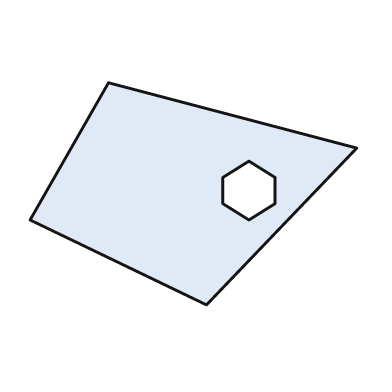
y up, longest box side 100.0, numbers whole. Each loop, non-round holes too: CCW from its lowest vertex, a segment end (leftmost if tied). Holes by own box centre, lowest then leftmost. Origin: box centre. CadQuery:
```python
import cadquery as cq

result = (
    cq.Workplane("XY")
    .moveTo(4.0, -34.0)
    .lineTo(50.0, 14.0)
    .lineTo(-26.0, 34.0)
    .lineTo(-50.0, -8.0)
    .close()
    .moveTo(17.0, -8.0)
    .lineTo(25.0, -3.0)
    .lineTo(25.0, 5.0)
    .lineTo(17.0, 10.0)
    .lineTo(9.0, 5.0)
    .lineTo(9.0, -3.0)
    .close()
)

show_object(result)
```